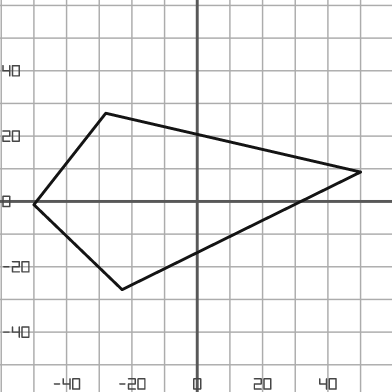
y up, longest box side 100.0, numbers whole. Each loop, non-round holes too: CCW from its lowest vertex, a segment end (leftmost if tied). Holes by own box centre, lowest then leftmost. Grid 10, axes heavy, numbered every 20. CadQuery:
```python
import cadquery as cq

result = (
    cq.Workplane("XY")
    .moveTo(-23.0, -27.0)
    .lineTo(50.0, 9.0)
    .lineTo(-28.0, 27.0)
    .lineTo(-50.0, -1.0)
    .close()
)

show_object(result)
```